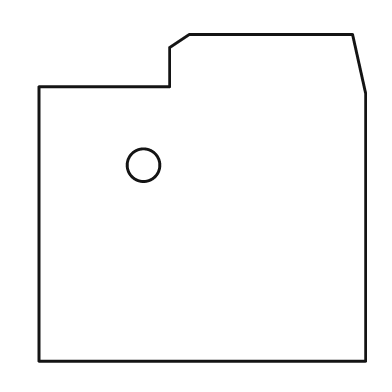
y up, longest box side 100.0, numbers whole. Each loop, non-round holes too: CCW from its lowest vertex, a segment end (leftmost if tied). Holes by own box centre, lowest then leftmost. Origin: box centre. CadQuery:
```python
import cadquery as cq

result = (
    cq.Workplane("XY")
    .moveTo(-50.0, -50.0)
    .lineTo(50.0, -50.0)
    .lineTo(50.0, 32.0)
    .lineTo(46.0, 50.0)
    .lineTo(-4.0, 50.0)
    .lineTo(-10.0, 46.0)
    .lineTo(-10.0, 34.0)
    .lineTo(-50.0, 34.0)
    .close()
    .moveTo(-18.0, 10.0)
    .circle(5.0)
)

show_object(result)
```